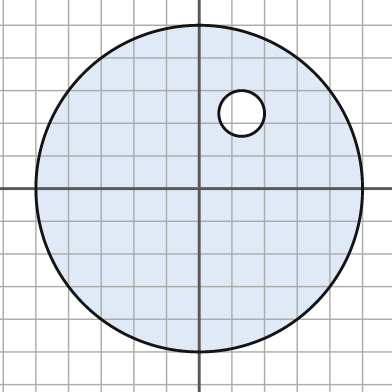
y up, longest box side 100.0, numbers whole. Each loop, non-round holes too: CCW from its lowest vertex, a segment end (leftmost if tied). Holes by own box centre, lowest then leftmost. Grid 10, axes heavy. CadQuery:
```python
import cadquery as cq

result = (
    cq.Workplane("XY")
    .moveTo(0.0, 0.0)
    .circle(50.0)
    .moveTo(13.0, 23.0)
    .circle(7.0)
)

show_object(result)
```